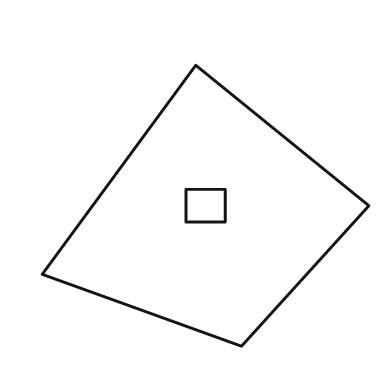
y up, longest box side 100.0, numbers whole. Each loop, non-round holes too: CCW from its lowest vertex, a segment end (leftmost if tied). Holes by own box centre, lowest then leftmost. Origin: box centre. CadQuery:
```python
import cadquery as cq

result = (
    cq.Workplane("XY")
    .moveTo(11.0, -43.0)
    .lineTo(50.0, 0.0)
    .lineTo(-3.0, 43.0)
    .lineTo(-50.0, -21.0)
    .close()
    .moveTo(-6.0, -5.0)
    .lineTo(6.0, -5.0)
    .lineTo(6.0, 5.0)
    .lineTo(-6.0, 5.0)
    .close()
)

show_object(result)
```